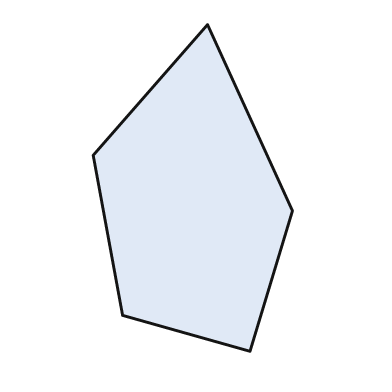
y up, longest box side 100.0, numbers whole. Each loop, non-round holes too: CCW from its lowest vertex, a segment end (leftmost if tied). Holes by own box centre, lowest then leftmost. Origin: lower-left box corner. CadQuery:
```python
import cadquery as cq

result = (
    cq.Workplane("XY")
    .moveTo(48.0, 0.0)
    .lineTo(61.0, 43.0)
    .lineTo(35.0, 100.0)
    .lineTo(0.0, 60.0)
    .lineTo(9.0, 11.0)
    .close()
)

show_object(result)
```